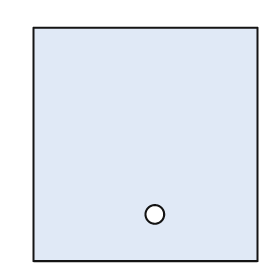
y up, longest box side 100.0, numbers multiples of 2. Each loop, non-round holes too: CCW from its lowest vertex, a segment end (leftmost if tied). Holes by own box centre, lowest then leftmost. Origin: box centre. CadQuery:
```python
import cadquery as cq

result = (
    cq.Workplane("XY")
    .moveTo(-48.0, -50.0)
    .lineTo(48.0, -50.0)
    .lineTo(48.0, 50.0)
    .lineTo(-48.0, 50.0)
    .close()
    .moveTo(4.0, -30.0)
    .circle(4.0)
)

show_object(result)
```